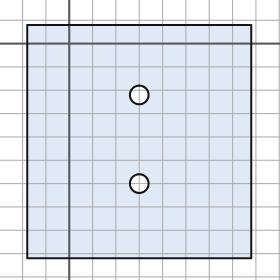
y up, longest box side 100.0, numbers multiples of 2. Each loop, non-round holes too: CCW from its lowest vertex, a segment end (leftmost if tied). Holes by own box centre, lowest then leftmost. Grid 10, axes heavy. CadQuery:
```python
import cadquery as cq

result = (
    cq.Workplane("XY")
    .moveTo(-18.0, -92.0)
    .lineTo(78.0, -92.0)
    .lineTo(78.0, 8.0)
    .lineTo(-18.0, 8.0)
    .close()
    .moveTo(30.0, -60.0)
    .circle(4.0)
    .moveTo(30.0, -22.0)
    .circle(4.0)
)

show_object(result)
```